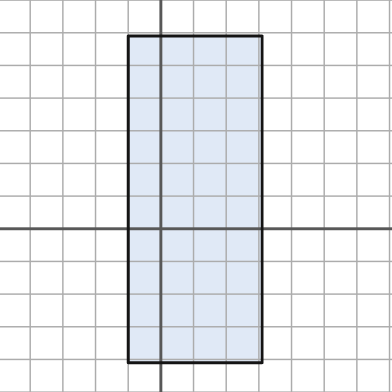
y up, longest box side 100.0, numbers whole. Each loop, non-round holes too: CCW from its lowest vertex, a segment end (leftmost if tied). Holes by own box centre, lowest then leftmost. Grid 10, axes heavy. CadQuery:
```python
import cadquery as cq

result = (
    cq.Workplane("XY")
    .moveTo(-10.0, -41.0)
    .lineTo(31.0, -41.0)
    .lineTo(31.0, 59.0)
    .lineTo(-10.0, 59.0)
    .close()
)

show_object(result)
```